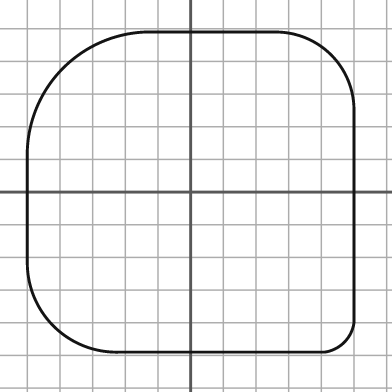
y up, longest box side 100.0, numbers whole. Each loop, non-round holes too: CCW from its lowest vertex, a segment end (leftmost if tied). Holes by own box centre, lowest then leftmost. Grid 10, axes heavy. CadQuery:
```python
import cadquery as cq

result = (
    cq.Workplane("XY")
    .moveTo(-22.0, -49.0)
    .lineTo(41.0, -49.0)
    .threePointArc((47.0, -46.0), (50.0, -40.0))
    .lineTo(50.0, 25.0)
    .threePointArc((43.0, 42.0), (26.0, 49.0))
    .lineTo(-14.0, 49.0)
    .threePointArc((-39.0, 38.0), (-50.0, 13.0))
    .lineTo(-50.0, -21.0)
    .threePointArc((-42.0, -41.0), (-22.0, -49.0))
    .close()
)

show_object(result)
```